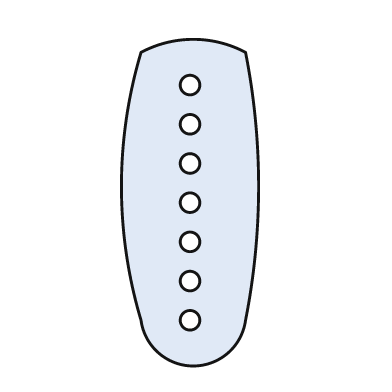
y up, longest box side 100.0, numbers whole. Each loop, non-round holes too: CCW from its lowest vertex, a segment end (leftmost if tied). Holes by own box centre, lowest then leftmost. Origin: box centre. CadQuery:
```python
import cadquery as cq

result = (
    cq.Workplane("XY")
    .moveTo(-15.0, -36.0)
    .threePointArc((1.0, -50.0), (17.0, -36.0))
    .threePointArc((21.0, 5.0), (17.0, 46.0))
    .threePointArc((1.0, 50.0), (-15.0, 46.0))
    .threePointArc((-21.0, 5.0), (-15.0, -36.0))
    .close()
    .moveTo(0.0, -36.0)
    .circle(3.0)
    .moveTo(0.0, -24.0)
    .circle(3.0)
    .moveTo(0.0, -12.0)
    .circle(3.0)
    .moveTo(0.0, 0.0)
    .circle(3.0)
    .moveTo(0.0, 12.0)
    .circle(3.0)
    .moveTo(0.0, 24.0)
    .circle(3.0)
    .moveTo(0.0, 36.0)
    .circle(3.0)
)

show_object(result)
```